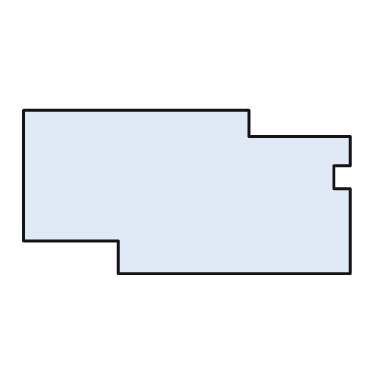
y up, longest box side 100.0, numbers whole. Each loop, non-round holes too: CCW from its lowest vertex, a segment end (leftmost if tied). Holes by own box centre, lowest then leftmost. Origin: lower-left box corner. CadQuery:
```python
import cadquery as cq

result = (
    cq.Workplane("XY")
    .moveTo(29.0, 0.0)
    .lineTo(100.0, 0.0)
    .lineTo(100.0, 26.0)
    .lineTo(95.0, 26.0)
    .lineTo(95.0, 33.0)
    .lineTo(100.0, 33.0)
    .lineTo(100.0, 42.0)
    .lineTo(69.0, 42.0)
    .lineTo(69.0, 50.0)
    .lineTo(0.0, 50.0)
    .lineTo(0.0, 10.0)
    .lineTo(29.0, 10.0)
    .close()
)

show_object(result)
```